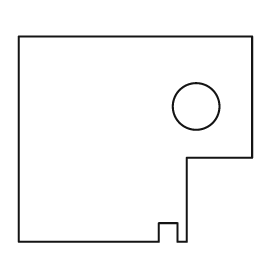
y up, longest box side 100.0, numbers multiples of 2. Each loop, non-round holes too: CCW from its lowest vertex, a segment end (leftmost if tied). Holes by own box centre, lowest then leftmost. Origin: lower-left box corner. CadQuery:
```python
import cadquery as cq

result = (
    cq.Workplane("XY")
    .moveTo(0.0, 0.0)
    .lineTo(60.0, 0.0)
    .lineTo(60.0, 8.0)
    .lineTo(68.0, 8.0)
    .lineTo(68.0, 0.0)
    .lineTo(72.0, 0.0)
    .lineTo(72.0, 36.0)
    .lineTo(100.0, 36.0)
    .lineTo(100.0, 88.0)
    .lineTo(0.0, 88.0)
    .close()
    .moveTo(76.0, 58.0)
    .circle(10.0)
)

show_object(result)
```